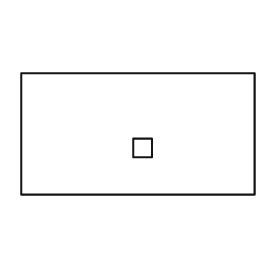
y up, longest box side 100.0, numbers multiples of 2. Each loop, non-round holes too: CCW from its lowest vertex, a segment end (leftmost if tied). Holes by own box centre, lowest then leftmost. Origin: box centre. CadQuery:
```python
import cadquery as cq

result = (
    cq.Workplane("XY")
    .moveTo(-50.0, -26.0)
    .lineTo(50.0, -26.0)
    .lineTo(50.0, 26.0)
    .lineTo(-50.0, 26.0)
    .close()
    .moveTo(-2.0, -10.0)
    .lineTo(6.0, -10.0)
    .lineTo(6.0, -2.0)
    .lineTo(-2.0, -2.0)
    .close()
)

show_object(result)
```